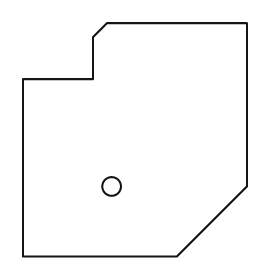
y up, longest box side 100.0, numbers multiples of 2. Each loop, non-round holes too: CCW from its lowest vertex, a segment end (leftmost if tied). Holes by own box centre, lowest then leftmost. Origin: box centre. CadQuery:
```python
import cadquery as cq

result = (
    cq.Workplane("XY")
    .moveTo(-48.0, -50.0)
    .lineTo(18.0, -50.0)
    .lineTo(48.0, -20.0)
    .lineTo(48.0, 50.0)
    .lineTo(-12.0, 50.0)
    .lineTo(-18.0, 44.0)
    .lineTo(-18.0, 26.0)
    .lineTo(-48.0, 26.0)
    .close()
    .moveTo(-10.0, -20.0)
    .circle(4.0)
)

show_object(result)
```